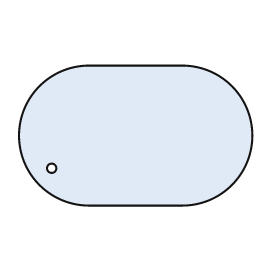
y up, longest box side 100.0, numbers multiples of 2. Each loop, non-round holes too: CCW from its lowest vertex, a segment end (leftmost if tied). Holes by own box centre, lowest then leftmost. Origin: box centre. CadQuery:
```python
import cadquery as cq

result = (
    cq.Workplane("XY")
    .moveTo(-20.0, -30.0)
    .lineTo(20.0, -30.0)
    .threePointArc((50.0, 0.0), (20.0, 30.0))
    .lineTo(-20.0, 30.0)
    .threePointArc((-50.0, 0.0), (-20.0, -30.0))
    .close()
    .moveTo(-36.0, -14.0)
    .circle(2.0)
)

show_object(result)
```